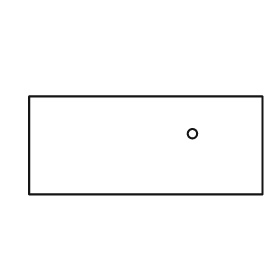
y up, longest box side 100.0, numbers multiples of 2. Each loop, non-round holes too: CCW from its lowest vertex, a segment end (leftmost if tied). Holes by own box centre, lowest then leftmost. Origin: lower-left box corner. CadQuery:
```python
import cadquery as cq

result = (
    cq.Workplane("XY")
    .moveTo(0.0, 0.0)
    .lineTo(100.0, 0.0)
    .lineTo(100.0, 42.0)
    .lineTo(0.0, 42.0)
    .close()
    .moveTo(70.0, 26.0)
    .circle(2.0)
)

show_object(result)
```